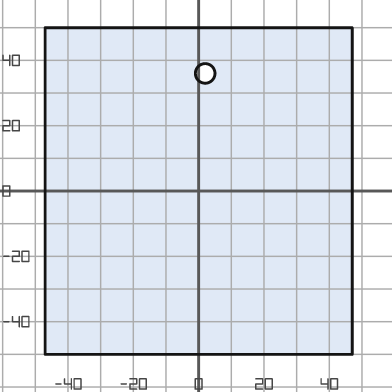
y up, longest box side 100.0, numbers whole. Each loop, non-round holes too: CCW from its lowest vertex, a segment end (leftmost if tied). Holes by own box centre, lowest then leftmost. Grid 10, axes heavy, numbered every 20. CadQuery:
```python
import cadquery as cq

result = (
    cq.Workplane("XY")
    .moveTo(-47.0, -50.0)
    .lineTo(47.0, -50.0)
    .lineTo(47.0, 50.0)
    .lineTo(-47.0, 50.0)
    .close()
    .moveTo(2.0, 36.0)
    .circle(3.0)
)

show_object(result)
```